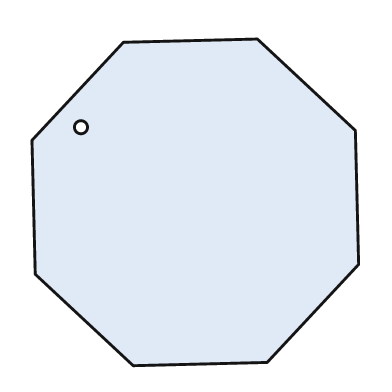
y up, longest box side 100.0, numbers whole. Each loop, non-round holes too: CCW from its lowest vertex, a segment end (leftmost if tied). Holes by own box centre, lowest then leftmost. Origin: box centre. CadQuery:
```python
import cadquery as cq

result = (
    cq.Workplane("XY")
    .moveTo(-19.0, -50.0)
    .lineTo(22.0, -49.0)
    .lineTo(50.0, -19.0)
    .lineTo(49.0, 22.0)
    .lineTo(19.0, 50.0)
    .lineTo(-22.0, 49.0)
    .lineTo(-50.0, 19.0)
    .lineTo(-49.0, -22.0)
    .close()
    .moveTo(-35.0, 23.0)
    .circle(2.0)
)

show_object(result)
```